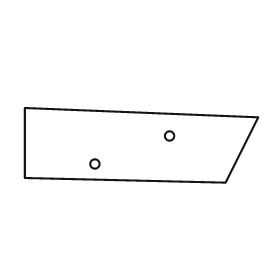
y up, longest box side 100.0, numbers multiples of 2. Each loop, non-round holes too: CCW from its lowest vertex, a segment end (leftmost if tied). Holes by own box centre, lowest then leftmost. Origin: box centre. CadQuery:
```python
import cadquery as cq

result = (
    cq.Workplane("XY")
    .moveTo(36.0, -16.0)
    .lineTo(50.0, 12.0)
    .lineTo(-50.0, 16.0)
    .lineTo(-50.0, -14.0)
    .close()
    .moveTo(-20.0, -8.0)
    .circle(2.0)
    .moveTo(12.0, 4.0)
    .circle(2.0)
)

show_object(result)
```